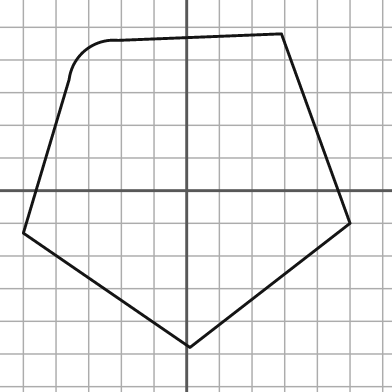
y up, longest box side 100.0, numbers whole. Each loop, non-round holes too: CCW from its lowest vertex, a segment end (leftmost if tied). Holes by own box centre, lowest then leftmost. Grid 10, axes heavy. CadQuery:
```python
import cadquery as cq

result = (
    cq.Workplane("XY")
    .moveTo(1.0, -48.0)
    .lineTo(50.0, -10.0)
    .lineTo(29.0, 48.0)
    .lineTo(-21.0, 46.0)
    .threePointArc((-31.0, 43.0), (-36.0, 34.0))
    .lineTo(-50.0, -13.0)
    .close()
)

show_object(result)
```